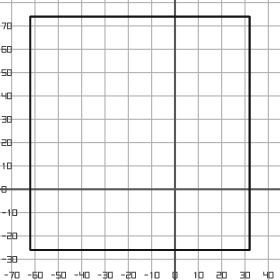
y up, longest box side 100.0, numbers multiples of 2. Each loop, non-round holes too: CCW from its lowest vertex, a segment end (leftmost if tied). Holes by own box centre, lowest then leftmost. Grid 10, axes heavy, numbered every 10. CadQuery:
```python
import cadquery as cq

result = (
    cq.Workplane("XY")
    .moveTo(-62.0, -26.0)
    .lineTo(32.0, -26.0)
    .lineTo(32.0, 74.0)
    .lineTo(-62.0, 74.0)
    .close()
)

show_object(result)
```